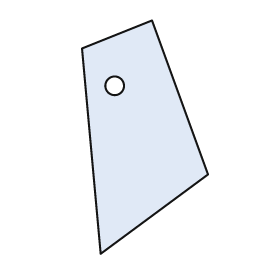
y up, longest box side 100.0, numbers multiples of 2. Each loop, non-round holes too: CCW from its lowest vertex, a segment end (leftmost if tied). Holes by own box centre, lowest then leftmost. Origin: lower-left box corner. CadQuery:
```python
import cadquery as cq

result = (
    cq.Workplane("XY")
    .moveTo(8.0, 0.0)
    .lineTo(54.0, 34.0)
    .lineTo(30.0, 100.0)
    .lineTo(0.0, 88.0)
    .close()
    .moveTo(14.0, 72.0)
    .circle(4.0)
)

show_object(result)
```